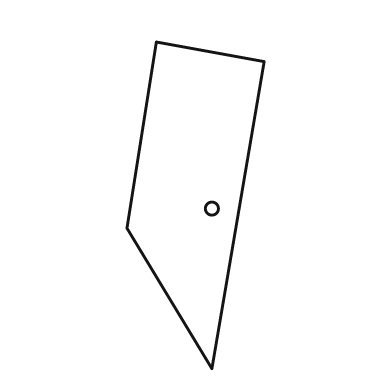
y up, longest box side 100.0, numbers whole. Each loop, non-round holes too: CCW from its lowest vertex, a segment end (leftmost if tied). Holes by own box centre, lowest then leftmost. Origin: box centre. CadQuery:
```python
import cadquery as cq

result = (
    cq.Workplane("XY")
    .moveTo(5.0, -50.0)
    .lineTo(21.0, 44.0)
    .lineTo(-12.0, 50.0)
    .lineTo(-21.0, -7.0)
    .close()
    .moveTo(5.0, -1.0)
    .circle(2.0)
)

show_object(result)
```